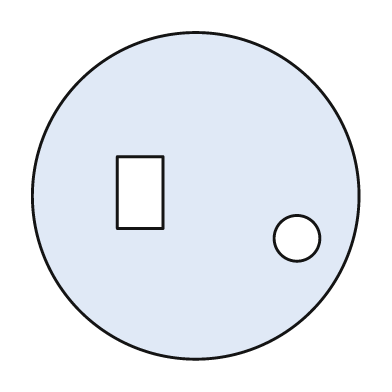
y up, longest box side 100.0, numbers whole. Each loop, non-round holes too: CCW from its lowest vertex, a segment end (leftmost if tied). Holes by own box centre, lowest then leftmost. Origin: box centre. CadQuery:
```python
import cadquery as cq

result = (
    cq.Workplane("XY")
    .moveTo(0.0, 0.0)
    .circle(50.0)
    .moveTo(31.0, -13.0)
    .circle(7.0)
    .moveTo(-24.0, -10.0)
    .lineTo(-10.0, -10.0)
    .lineTo(-10.0, 12.0)
    .lineTo(-24.0, 12.0)
    .close()
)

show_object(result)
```